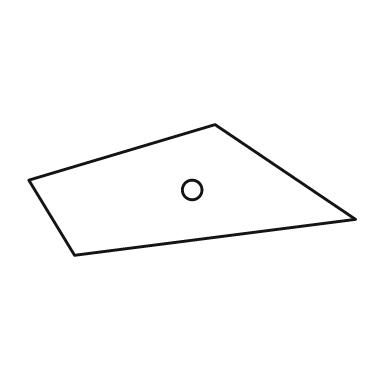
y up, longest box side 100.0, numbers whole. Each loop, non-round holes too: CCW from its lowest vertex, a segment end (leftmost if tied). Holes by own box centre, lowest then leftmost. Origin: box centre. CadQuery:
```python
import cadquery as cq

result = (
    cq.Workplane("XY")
    .moveTo(-36.0, -20.0)
    .lineTo(50.0, -9.0)
    .lineTo(7.0, 20.0)
    .lineTo(-50.0, 3.0)
    .close()
    .moveTo(0.0, 0.0)
    .circle(3.0)
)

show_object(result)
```